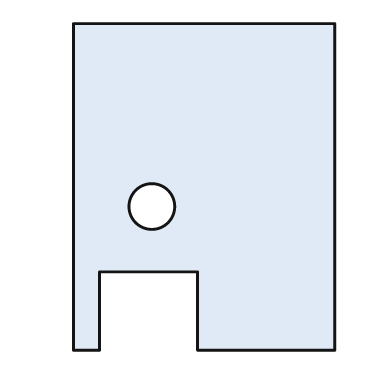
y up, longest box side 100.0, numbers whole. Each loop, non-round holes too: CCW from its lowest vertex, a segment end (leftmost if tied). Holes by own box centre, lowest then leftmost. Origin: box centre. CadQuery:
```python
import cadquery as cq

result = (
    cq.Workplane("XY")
    .moveTo(-40.0, -50.0)
    .lineTo(-32.0, -50.0)
    .lineTo(-32.0, -26.0)
    .lineTo(-2.0, -26.0)
    .lineTo(-2.0, -50.0)
    .lineTo(40.0, -50.0)
    .lineTo(40.0, 50.0)
    .lineTo(-40.0, 50.0)
    .close()
    .moveTo(-16.0, -6.0)
    .circle(7.0)
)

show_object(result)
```